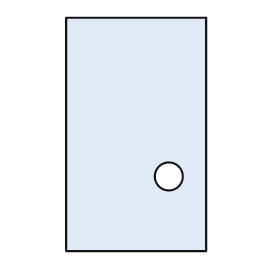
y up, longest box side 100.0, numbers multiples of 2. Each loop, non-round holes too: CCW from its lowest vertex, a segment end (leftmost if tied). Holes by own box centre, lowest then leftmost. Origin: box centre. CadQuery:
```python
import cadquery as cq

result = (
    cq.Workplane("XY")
    .moveTo(-30.0, -50.0)
    .lineTo(30.0, -50.0)
    .lineTo(30.0, 50.0)
    .lineTo(-30.0, 50.0)
    .close()
    .moveTo(14.0, -18.0)
    .circle(6.0)
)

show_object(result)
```